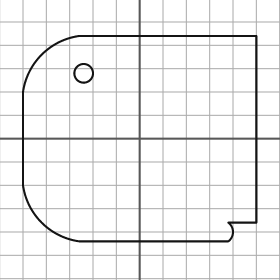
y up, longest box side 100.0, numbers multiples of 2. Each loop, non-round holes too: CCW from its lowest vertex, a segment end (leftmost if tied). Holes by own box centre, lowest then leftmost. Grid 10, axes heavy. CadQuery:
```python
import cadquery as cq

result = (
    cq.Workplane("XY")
    .moveTo(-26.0, -44.0)
    .lineTo(38.0, -44.0)
    .threePointArc((40.0, -40.0), (38.0, -36.0))
    .lineTo(50.0, -36.0)
    .lineTo(50.0, 44.0)
    .lineTo(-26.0, 44.0)
    .threePointArc((-42.0, 36.0), (-50.0, 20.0))
    .lineTo(-50.0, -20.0)
    .threePointArc((-42.0, -36.0), (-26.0, -44.0))
    .close()
    .moveTo(-24.0, 28.0)
    .circle(4.0)
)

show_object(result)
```